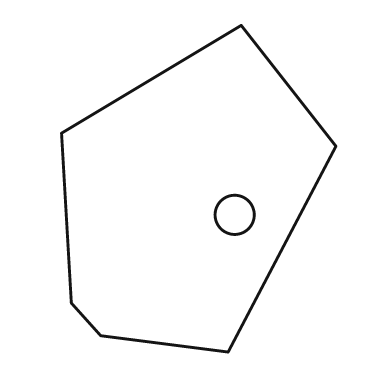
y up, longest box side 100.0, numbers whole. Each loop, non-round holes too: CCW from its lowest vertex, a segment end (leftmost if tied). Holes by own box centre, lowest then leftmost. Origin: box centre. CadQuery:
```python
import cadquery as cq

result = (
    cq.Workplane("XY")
    .moveTo(9.0, -50.0)
    .lineTo(42.0, 13.0)
    .lineTo(13.0, 50.0)
    .lineTo(-42.0, 17.0)
    .lineTo(-39.0, -35.0)
    .lineTo(-30.0, -45.0)
    .close()
    .moveTo(11.0, -8.0)
    .circle(6.0)
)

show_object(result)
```